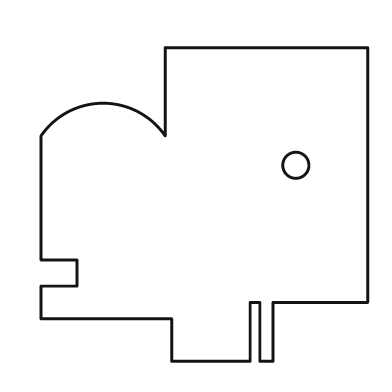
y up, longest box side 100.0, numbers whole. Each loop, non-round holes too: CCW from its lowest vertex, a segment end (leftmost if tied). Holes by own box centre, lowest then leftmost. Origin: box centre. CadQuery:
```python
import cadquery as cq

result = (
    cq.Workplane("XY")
    .moveTo(-10.0, -48.0)
    .lineTo(14.0, -48.0)
    .lineTo(14.0, -30.0)
    .lineTo(17.0, -30.0)
    .lineTo(17.0, -48.0)
    .lineTo(21.0, -48.0)
    .lineTo(21.0, -30.0)
    .lineTo(50.0, -30.0)
    .lineTo(50.0, 48.0)
    .lineTo(-12.0, 48.0)
    .lineTo(-12.0, 21.0)
    .threePointArc((-31.0, 31.0), (-50.0, 21.0))
    .lineTo(-50.0, -17.0)
    .lineTo(-39.0, -17.0)
    .lineTo(-39.0, -25.0)
    .lineTo(-50.0, -25.0)
    .lineTo(-50.0, -35.0)
    .lineTo(-10.0, -35.0)
    .close()
    .moveTo(28.0, 12.0)
    .circle(4.0)
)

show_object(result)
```